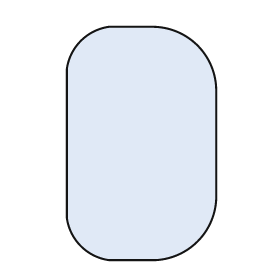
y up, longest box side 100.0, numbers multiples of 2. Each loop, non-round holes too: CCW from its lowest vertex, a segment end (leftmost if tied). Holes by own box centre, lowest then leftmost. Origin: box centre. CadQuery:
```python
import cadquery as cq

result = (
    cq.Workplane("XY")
    .moveTo(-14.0, -50.0)
    .lineTo(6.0, -50.0)
    .threePointArc((24.0, -42.0), (32.0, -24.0))
    .lineTo(32.0, 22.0)
    .threePointArc((24.0, 42.0), (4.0, 50.0))
    .lineTo(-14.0, 50.0)
    .threePointArc((-26.0, 44.0), (-32.0, 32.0))
    .lineTo(-32.0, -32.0)
    .threePointArc((-26.0, -44.0), (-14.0, -50.0))
    .close()
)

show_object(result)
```